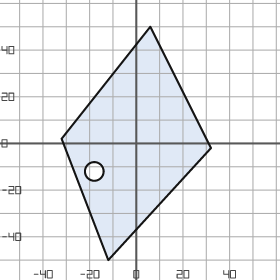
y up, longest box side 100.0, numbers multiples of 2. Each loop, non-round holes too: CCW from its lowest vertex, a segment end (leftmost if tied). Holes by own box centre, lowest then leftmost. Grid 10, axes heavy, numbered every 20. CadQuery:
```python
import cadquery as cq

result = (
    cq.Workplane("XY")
    .moveTo(-12.0, -50.0)
    .lineTo(32.0, -2.0)
    .lineTo(6.0, 50.0)
    .lineTo(-32.0, 2.0)
    .close()
    .moveTo(-18.0, -12.0)
    .circle(4.0)
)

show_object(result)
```